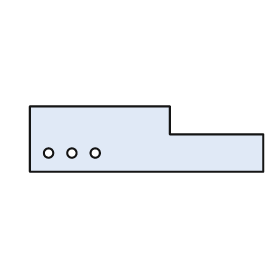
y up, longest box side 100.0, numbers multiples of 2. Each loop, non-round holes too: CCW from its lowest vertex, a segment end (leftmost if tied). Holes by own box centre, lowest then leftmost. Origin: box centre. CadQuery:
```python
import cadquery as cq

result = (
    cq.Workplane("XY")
    .moveTo(-50.0, -14.0)
    .lineTo(50.0, -14.0)
    .lineTo(50.0, 2.0)
    .lineTo(10.0, 2.0)
    .lineTo(10.0, 14.0)
    .lineTo(-50.0, 14.0)
    .close()
    .moveTo(-42.0, -6.0)
    .circle(2.0)
    .moveTo(-32.0, -6.0)
    .circle(2.0)
    .moveTo(-22.0, -6.0)
    .circle(2.0)
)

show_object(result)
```